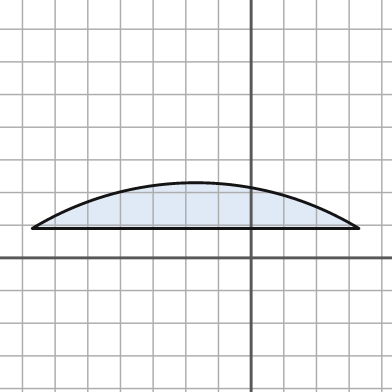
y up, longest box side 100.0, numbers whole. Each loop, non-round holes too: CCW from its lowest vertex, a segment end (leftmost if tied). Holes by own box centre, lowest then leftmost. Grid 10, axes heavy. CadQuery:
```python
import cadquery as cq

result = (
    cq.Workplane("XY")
    .moveTo(-67.0, 9.0)
    .lineTo(33.0, 9.0)
    .threePointArc((-17.0, 23.0), (-67.0, 9.0))
    .close()
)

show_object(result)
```